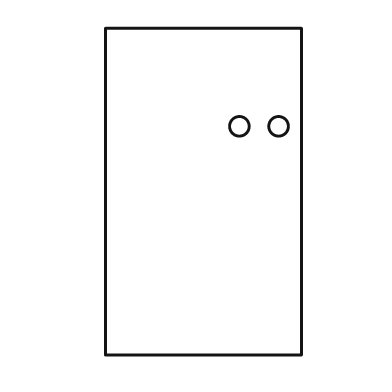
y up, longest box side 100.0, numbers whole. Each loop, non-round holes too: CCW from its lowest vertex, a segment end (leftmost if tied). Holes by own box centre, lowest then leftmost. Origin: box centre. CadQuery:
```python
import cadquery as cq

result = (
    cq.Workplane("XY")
    .moveTo(-30.0, -50.0)
    .lineTo(30.0, -50.0)
    .lineTo(30.0, 50.0)
    .lineTo(-30.0, 50.0)
    .close()
    .moveTo(11.0, 20.0)
    .circle(3.0)
    .moveTo(23.0, 20.0)
    .circle(3.0)
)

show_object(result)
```